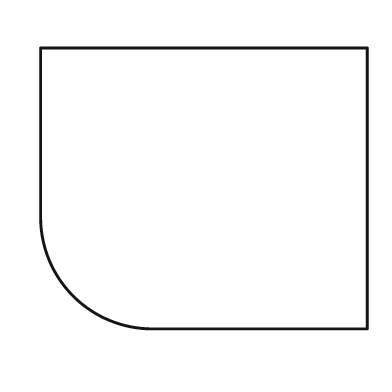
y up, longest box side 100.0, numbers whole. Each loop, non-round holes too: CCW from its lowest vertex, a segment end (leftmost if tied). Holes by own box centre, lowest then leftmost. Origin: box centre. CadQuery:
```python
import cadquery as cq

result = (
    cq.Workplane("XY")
    .moveTo(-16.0, -43.0)
    .lineTo(50.0, -43.0)
    .lineTo(50.0, 43.0)
    .lineTo(-50.0, 43.0)
    .lineTo(-50.0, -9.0)
    .threePointArc((-40.0, -33.0), (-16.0, -43.0))
    .close()
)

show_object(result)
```